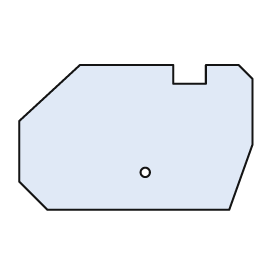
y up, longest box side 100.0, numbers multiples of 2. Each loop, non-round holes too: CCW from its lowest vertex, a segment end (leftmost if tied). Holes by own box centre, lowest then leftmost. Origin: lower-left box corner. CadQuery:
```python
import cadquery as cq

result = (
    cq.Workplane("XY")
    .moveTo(12.0, 0.0)
    .lineTo(90.0, 0.0)
    .lineTo(100.0, 28.0)
    .lineTo(100.0, 56.0)
    .lineTo(94.0, 62.0)
    .lineTo(80.0, 62.0)
    .lineTo(80.0, 54.0)
    .lineTo(66.0, 54.0)
    .lineTo(66.0, 62.0)
    .lineTo(26.0, 62.0)
    .lineTo(0.0, 38.0)
    .lineTo(0.0, 12.0)
    .close()
    .moveTo(54.0, 16.0)
    .circle(2.0)
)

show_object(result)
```